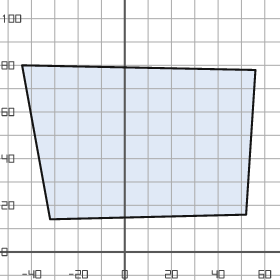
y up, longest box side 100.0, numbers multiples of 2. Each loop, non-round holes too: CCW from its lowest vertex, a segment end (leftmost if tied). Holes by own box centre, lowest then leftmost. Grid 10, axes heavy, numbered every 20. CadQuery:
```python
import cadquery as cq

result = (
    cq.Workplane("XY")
    .moveTo(-32.0, 14.0)
    .lineTo(52.0, 16.0)
    .lineTo(56.0, 78.0)
    .lineTo(-44.0, 80.0)
    .close()
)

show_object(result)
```